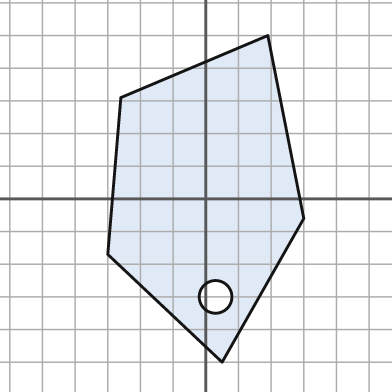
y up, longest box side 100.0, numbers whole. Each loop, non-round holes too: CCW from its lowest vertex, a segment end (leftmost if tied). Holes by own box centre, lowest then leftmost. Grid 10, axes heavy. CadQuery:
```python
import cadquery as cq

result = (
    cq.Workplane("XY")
    .moveTo(5.0, -50.0)
    .lineTo(30.0, -6.0)
    .lineTo(19.0, 50.0)
    .lineTo(-26.0, 31.0)
    .lineTo(-30.0, -17.0)
    .close()
    .moveTo(3.0, -30.0)
    .circle(5.0)
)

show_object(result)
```